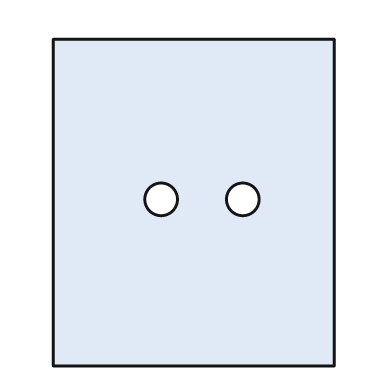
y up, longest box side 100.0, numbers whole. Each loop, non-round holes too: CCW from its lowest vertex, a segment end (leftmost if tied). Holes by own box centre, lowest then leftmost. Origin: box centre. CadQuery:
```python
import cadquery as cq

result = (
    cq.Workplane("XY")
    .moveTo(-43.0, -50.0)
    .lineTo(43.0, -50.0)
    .lineTo(43.0, 50.0)
    .lineTo(-43.0, 50.0)
    .close()
    .moveTo(-10.0, 1.0)
    .circle(5.0)
    .moveTo(15.0, 1.0)
    .circle(5.0)
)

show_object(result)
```